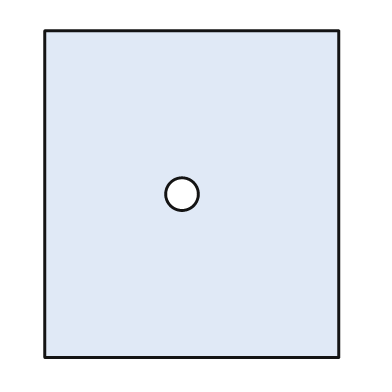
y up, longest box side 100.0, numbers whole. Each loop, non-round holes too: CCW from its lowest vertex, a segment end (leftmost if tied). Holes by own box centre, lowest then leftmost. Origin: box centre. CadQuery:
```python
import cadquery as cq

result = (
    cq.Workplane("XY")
    .moveTo(-45.0, -50.0)
    .lineTo(45.0, -50.0)
    .lineTo(45.0, 50.0)
    .lineTo(-45.0, 50.0)
    .close()
    .moveTo(-3.0, 0.0)
    .circle(5.0)
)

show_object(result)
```